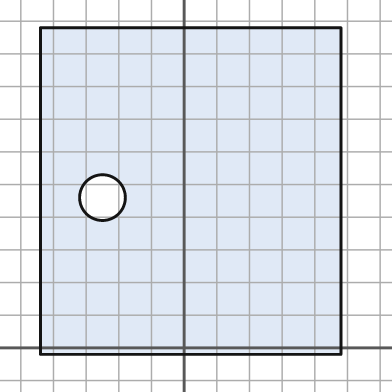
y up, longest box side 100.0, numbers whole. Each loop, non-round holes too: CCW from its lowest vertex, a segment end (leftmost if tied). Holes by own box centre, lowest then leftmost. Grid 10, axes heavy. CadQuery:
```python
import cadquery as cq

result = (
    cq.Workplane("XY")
    .moveTo(-44.0, -2.0)
    .lineTo(48.0, -2.0)
    .lineTo(48.0, 98.0)
    .lineTo(-44.0, 98.0)
    .close()
    .moveTo(-25.0, 46.0)
    .circle(7.0)
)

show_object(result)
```